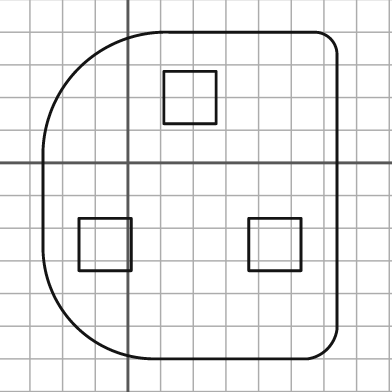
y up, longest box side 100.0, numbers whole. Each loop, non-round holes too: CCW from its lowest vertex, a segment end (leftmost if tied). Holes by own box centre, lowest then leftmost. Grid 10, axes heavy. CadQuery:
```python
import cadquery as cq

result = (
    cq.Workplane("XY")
    .moveTo(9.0, -60.0)
    .lineTo(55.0, -60.0)
    .threePointArc((61.0, -57.0), (64.0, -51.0))
    .lineTo(64.0, 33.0)
    .threePointArc((62.0, 38.0), (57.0, 40.0))
    .lineTo(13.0, 40.0)
    .threePointArc((-15.0, 29.0), (-26.0, 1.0))
    .lineTo(-26.0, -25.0)
    .threePointArc((-16.0, -50.0), (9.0, -60.0))
    .close()
    .moveTo(-15.0, -33.0)
    .lineTo(1.0, -33.0)
    .lineTo(1.0, -17.0)
    .lineTo(-15.0, -17.0)
    .close()
    .moveTo(37.0, -33.0)
    .lineTo(53.0, -33.0)
    .lineTo(53.0, -17.0)
    .lineTo(37.0, -17.0)
    .close()
    .moveTo(11.0, 12.0)
    .lineTo(27.0, 12.0)
    .lineTo(27.0, 28.0)
    .lineTo(11.0, 28.0)
    .close()
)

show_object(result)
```